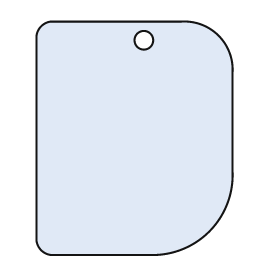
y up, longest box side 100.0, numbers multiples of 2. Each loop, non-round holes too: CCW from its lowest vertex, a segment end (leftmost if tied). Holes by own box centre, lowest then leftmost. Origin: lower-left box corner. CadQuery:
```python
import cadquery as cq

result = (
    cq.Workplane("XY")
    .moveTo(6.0, 0.0)
    .lineTo(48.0, 0.0)
    .threePointArc((74.0, 10.0), (84.0, 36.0))
    .lineTo(84.0, 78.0)
    .threePointArc((78.0, 94.0), (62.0, 100.0))
    .lineTo(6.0, 100.0)
    .threePointArc((2.0, 98.0), (0.0, 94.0))
    .lineTo(0.0, 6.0)
    .threePointArc((2.0, 2.0), (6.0, 0.0))
    .close()
    .moveTo(46.0, 92.0)
    .circle(4.0)
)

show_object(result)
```